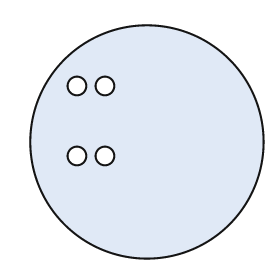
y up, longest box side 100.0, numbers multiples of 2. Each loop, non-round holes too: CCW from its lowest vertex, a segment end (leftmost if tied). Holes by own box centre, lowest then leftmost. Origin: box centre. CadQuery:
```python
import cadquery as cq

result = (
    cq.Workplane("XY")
    .moveTo(0.0, 0.0)
    .circle(50.0)
    .moveTo(-30.0, -6.0)
    .circle(4.0)
    .moveTo(-18.0, -6.0)
    .circle(4.0)
    .moveTo(-30.0, 24.0)
    .circle(4.0)
    .moveTo(-18.0, 24.0)
    .circle(4.0)
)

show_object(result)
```